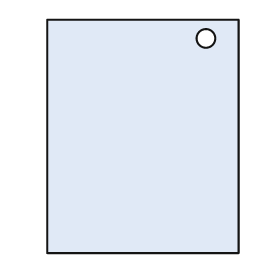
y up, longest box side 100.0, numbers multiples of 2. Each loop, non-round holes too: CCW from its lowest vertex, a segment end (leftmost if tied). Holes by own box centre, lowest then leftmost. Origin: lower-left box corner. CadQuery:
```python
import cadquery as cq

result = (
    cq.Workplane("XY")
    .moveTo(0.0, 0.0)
    .lineTo(82.0, 0.0)
    .lineTo(82.0, 100.0)
    .lineTo(0.0, 100.0)
    .close()
    .moveTo(68.0, 92.0)
    .circle(4.0)
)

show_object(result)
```